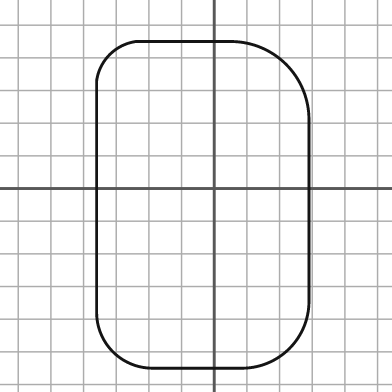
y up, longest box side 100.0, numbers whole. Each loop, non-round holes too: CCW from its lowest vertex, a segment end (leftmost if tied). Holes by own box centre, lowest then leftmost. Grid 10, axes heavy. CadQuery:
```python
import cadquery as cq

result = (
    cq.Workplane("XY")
    .moveTo(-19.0, -55.0)
    .lineTo(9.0, -55.0)
    .threePointArc((23.0, -49.0), (29.0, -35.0))
    .lineTo(29.0, 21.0)
    .threePointArc((22.0, 38.0), (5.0, 45.0))
    .lineTo(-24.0, 45.0)
    .threePointArc((-32.0, 41.0), (-36.0, 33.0))
    .lineTo(-36.0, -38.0)
    .threePointArc((-31.0, -50.0), (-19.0, -55.0))
    .close()
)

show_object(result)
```